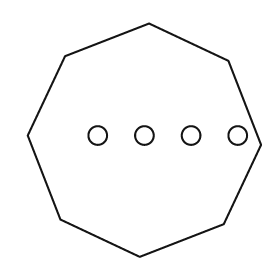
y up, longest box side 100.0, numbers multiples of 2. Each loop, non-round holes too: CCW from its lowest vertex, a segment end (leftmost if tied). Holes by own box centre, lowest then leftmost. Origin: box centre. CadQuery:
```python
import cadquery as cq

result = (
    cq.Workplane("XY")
    .moveTo(-2.0, -50.0)
    .lineTo(34.0, -36.0)
    .lineTo(50.0, -2.0)
    .lineTo(36.0, 34.0)
    .lineTo(2.0, 50.0)
    .lineTo(-34.0, 36.0)
    .lineTo(-50.0, 2.0)
    .lineTo(-36.0, -34.0)
    .close()
    .moveTo(-20.0, 2.0)
    .circle(4.0)
    .moveTo(0.0, 2.0)
    .circle(4.0)
    .moveTo(20.0, 2.0)
    .circle(4.0)
    .moveTo(40.0, 2.0)
    .circle(4.0)
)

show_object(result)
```